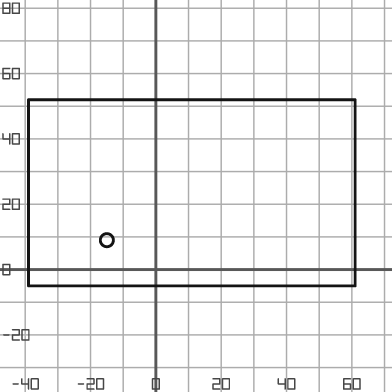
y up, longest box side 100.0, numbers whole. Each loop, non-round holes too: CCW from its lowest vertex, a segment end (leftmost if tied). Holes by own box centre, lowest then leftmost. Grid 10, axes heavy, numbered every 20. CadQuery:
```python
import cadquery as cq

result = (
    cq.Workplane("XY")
    .moveTo(-39.0, -5.0)
    .lineTo(61.0, -5.0)
    .lineTo(61.0, 52.0)
    .lineTo(-39.0, 52.0)
    .close()
    .moveTo(-15.0, 9.0)
    .circle(2.0)
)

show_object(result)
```